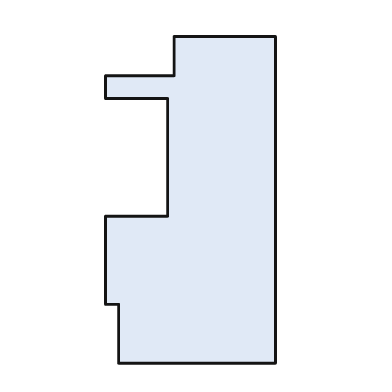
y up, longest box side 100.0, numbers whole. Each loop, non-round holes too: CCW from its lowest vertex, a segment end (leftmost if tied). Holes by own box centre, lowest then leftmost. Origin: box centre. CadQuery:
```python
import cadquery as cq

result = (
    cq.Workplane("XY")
    .moveTo(-22.0, -50.0)
    .lineTo(26.0, -50.0)
    .lineTo(26.0, 50.0)
    .lineTo(-5.0, 50.0)
    .lineTo(-5.0, 38.0)
    .lineTo(-26.0, 38.0)
    .lineTo(-26.0, 31.0)
    .lineTo(-7.0, 31.0)
    .lineTo(-7.0, -5.0)
    .lineTo(-26.0, -5.0)
    .lineTo(-26.0, -32.0)
    .lineTo(-22.0, -32.0)
    .close()
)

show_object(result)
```